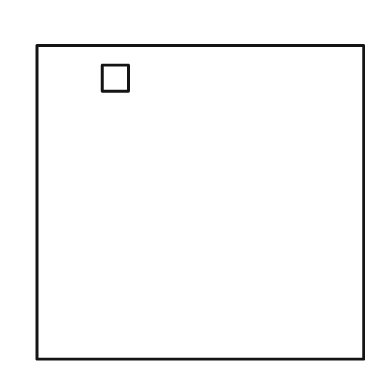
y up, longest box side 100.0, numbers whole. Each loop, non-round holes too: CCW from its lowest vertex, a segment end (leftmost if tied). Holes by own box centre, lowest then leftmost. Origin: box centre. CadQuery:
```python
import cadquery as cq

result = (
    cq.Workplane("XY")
    .moveTo(-50.0, -48.0)
    .lineTo(50.0, -48.0)
    .lineTo(50.0, 48.0)
    .lineTo(-50.0, 48.0)
    .close()
    .moveTo(-30.0, 34.0)
    .lineTo(-22.0, 34.0)
    .lineTo(-22.0, 42.0)
    .lineTo(-30.0, 42.0)
    .close()
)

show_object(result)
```